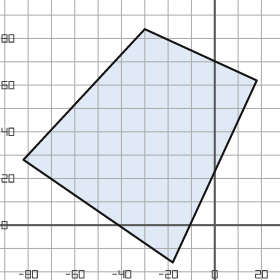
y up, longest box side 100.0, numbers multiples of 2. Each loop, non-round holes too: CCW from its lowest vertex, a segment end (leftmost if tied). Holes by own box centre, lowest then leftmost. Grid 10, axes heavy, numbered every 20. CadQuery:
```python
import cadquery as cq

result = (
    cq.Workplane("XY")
    .moveTo(-18.0, -16.0)
    .lineTo(18.0, 62.0)
    .lineTo(-30.0, 84.0)
    .lineTo(-82.0, 28.0)
    .close()
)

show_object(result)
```